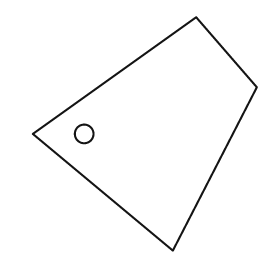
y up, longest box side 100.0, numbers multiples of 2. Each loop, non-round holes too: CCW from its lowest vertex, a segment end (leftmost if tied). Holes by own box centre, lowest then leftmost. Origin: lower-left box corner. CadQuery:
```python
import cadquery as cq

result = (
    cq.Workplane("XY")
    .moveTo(60.0, 0.0)
    .lineTo(96.0, 70.0)
    .lineTo(70.0, 100.0)
    .lineTo(0.0, 50.0)
    .close()
    .moveTo(22.0, 50.0)
    .circle(4.0)
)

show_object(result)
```